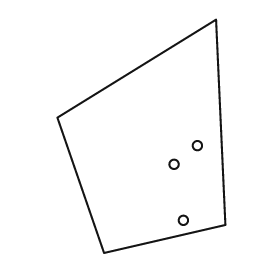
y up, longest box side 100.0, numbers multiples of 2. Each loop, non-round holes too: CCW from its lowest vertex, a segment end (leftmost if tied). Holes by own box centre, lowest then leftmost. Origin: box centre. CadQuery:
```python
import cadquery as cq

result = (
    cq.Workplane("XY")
    .moveTo(-16.0, -50.0)
    .lineTo(36.0, -38.0)
    .lineTo(32.0, 50.0)
    .lineTo(-36.0, 8.0)
    .close()
    .moveTo(18.0, -36.0)
    .circle(2.0)
    .moveTo(14.0, -12.0)
    .circle(2.0)
    .moveTo(24.0, -4.0)
    .circle(2.0)
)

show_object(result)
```